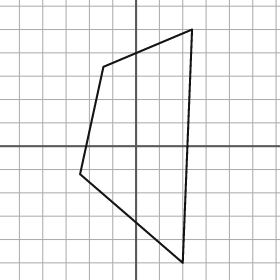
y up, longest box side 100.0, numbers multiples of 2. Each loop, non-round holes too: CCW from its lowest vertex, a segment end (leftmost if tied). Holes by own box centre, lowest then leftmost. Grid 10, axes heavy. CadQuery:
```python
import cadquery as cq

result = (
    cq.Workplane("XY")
    .moveTo(20.0, -50.0)
    .lineTo(24.0, 50.0)
    .lineTo(-14.0, 34.0)
    .lineTo(-24.0, -12.0)
    .close()
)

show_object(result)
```